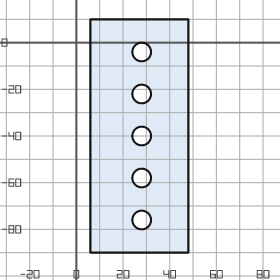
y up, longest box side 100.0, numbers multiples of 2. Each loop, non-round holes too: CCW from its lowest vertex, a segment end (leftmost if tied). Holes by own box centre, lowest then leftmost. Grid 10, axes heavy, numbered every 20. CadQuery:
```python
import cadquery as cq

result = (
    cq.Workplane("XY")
    .moveTo(6.0, -90.0)
    .lineTo(48.0, -90.0)
    .lineTo(48.0, 10.0)
    .lineTo(6.0, 10.0)
    .close()
    .moveTo(28.0, -76.0)
    .circle(4.0)
    .moveTo(28.0, -58.0)
    .circle(4.0)
    .moveTo(28.0, -40.0)
    .circle(4.0)
    .moveTo(28.0, -22.0)
    .circle(4.0)
    .moveTo(28.0, -4.0)
    .circle(4.0)
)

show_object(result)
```